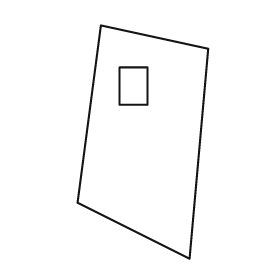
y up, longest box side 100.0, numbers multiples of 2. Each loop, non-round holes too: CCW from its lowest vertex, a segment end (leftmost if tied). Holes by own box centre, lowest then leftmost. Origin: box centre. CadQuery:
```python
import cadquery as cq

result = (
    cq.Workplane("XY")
    .moveTo(20.0, -50.0)
    .lineTo(28.0, 40.0)
    .lineTo(-18.0, 50.0)
    .lineTo(-28.0, -26.0)
    .close()
    .moveTo(-10.0, 16.0)
    .lineTo(2.0, 16.0)
    .lineTo(2.0, 32.0)
    .lineTo(-10.0, 32.0)
    .close()
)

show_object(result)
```